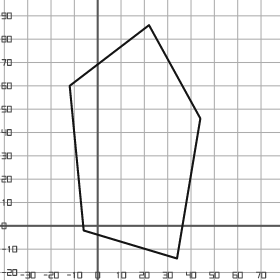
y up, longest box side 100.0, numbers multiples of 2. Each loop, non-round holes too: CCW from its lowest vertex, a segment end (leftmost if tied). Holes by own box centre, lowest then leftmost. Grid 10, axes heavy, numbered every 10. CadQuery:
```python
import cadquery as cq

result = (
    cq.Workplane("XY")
    .moveTo(34.0, -14.0)
    .lineTo(44.0, 46.0)
    .lineTo(22.0, 86.0)
    .lineTo(-12.0, 60.0)
    .lineTo(-6.0, -2.0)
    .close()
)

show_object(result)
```